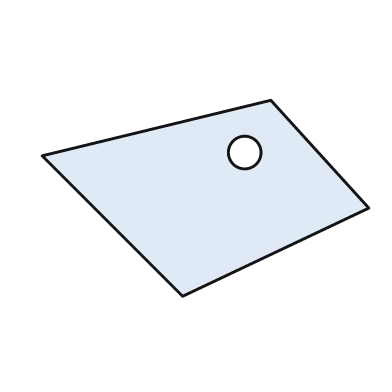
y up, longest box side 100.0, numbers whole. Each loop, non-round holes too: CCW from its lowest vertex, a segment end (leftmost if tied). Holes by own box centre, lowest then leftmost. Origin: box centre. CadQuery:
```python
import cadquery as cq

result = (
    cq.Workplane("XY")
    .moveTo(-7.0, -30.0)
    .lineTo(50.0, -3.0)
    .lineTo(20.0, 30.0)
    .lineTo(-50.0, 13.0)
    .close()
    .moveTo(12.0, 14.0)
    .circle(5.0)
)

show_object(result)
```